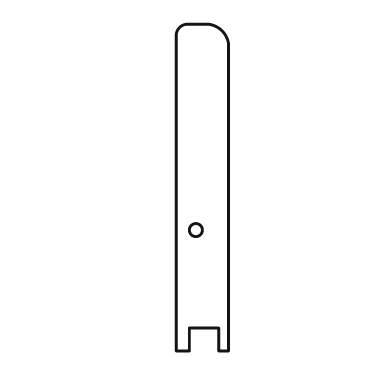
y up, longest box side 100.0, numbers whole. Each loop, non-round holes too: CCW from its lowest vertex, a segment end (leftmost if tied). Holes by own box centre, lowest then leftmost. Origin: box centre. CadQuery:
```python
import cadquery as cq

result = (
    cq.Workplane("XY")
    .moveTo(-8.0, -50.0)
    .lineTo(-4.0, -50.0)
    .lineTo(-4.0, -43.0)
    .lineTo(5.0, -43.0)
    .lineTo(5.0, -50.0)
    .lineTo(8.0, -50.0)
    .lineTo(8.0, 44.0)
    .threePointArc((6.0, 48.0), (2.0, 50.0))
    .lineTo(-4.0, 50.0)
    .threePointArc((-7.0, 49.0), (-8.0, 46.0))
    .close()
    .moveTo(-2.0, -13.0)
    .circle(2.0)
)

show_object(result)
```